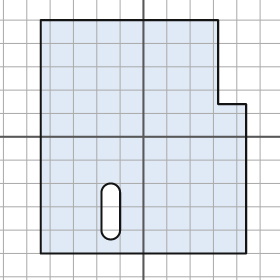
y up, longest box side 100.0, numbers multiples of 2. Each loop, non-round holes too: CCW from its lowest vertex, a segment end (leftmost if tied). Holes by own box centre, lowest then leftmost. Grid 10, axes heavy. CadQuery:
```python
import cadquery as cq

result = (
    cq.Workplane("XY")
    .moveTo(-44.0, -50.0)
    .lineTo(44.0, -50.0)
    .lineTo(44.0, 14.0)
    .lineTo(32.0, 14.0)
    .lineTo(32.0, 50.0)
    .lineTo(-44.0, 50.0)
    .close()
    .moveTo(-18.0, -40.0)
    .threePointArc((-14.0, -44.0), (-10.0, -40.0))
    .lineTo(-10.0, -24.0)
    .threePointArc((-14.0, -20.0), (-18.0, -24.0))
    .close()
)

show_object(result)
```